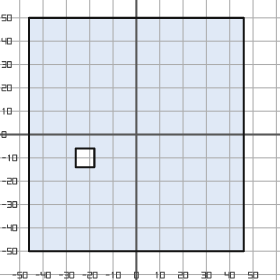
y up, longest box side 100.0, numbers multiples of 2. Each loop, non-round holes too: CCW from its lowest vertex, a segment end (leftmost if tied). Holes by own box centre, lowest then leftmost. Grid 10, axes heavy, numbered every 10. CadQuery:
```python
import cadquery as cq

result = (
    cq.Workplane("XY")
    .moveTo(-46.0, -50.0)
    .lineTo(46.0, -50.0)
    .lineTo(46.0, 50.0)
    .lineTo(-46.0, 50.0)
    .close()
    .moveTo(-26.0, -14.0)
    .lineTo(-18.0, -14.0)
    .lineTo(-18.0, -6.0)
    .lineTo(-26.0, -6.0)
    .close()
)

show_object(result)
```